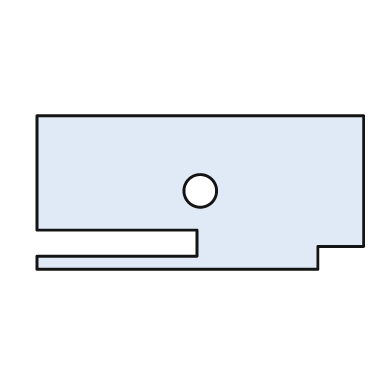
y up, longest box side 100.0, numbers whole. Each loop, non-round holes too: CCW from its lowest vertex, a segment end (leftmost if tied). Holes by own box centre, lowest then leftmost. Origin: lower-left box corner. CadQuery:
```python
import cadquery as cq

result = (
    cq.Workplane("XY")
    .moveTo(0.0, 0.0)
    .lineTo(86.0, 0.0)
    .lineTo(86.0, 7.0)
    .lineTo(100.0, 7.0)
    .lineTo(100.0, 47.0)
    .lineTo(0.0, 47.0)
    .lineTo(0.0, 12.0)
    .lineTo(49.0, 12.0)
    .lineTo(49.0, 4.0)
    .lineTo(0.0, 4.0)
    .close()
    .moveTo(50.0, 24.0)
    .circle(5.0)
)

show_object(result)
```